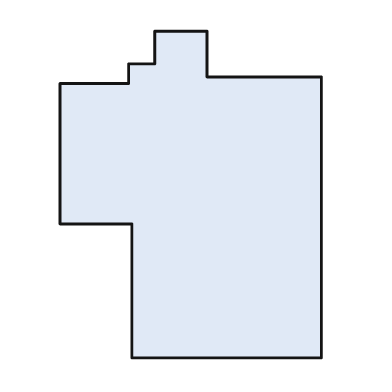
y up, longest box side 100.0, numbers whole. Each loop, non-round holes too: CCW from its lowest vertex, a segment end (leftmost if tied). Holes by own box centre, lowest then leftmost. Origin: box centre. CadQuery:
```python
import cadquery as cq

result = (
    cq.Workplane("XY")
    .moveTo(-18.0, -50.0)
    .lineTo(40.0, -50.0)
    .lineTo(40.0, 36.0)
    .lineTo(5.0, 36.0)
    .lineTo(5.0, 50.0)
    .lineTo(-11.0, 50.0)
    .lineTo(-11.0, 40.0)
    .lineTo(-19.0, 40.0)
    .lineTo(-19.0, 34.0)
    .lineTo(-40.0, 34.0)
    .lineTo(-40.0, -9.0)
    .lineTo(-18.0, -9.0)
    .close()
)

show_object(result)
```